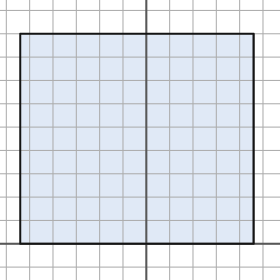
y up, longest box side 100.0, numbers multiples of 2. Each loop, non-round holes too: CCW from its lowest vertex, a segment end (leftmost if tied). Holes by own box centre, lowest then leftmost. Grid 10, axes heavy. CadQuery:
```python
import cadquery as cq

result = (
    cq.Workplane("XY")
    .moveTo(-54.0, 0.0)
    .lineTo(46.0, 0.0)
    .lineTo(46.0, 90.0)
    .lineTo(-54.0, 90.0)
    .close()
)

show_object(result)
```